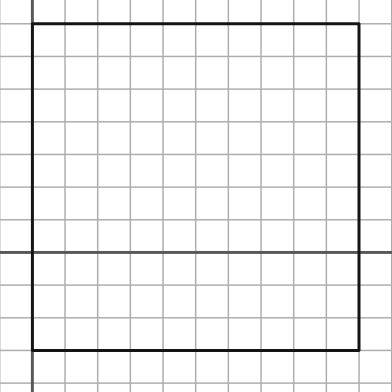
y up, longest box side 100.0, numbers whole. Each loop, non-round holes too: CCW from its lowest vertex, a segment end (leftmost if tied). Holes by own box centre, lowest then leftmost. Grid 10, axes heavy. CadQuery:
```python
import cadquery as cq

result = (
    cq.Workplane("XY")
    .moveTo(0.0, -30.0)
    .lineTo(100.0, -30.0)
    .lineTo(100.0, 70.0)
    .lineTo(0.0, 70.0)
    .close()
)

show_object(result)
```